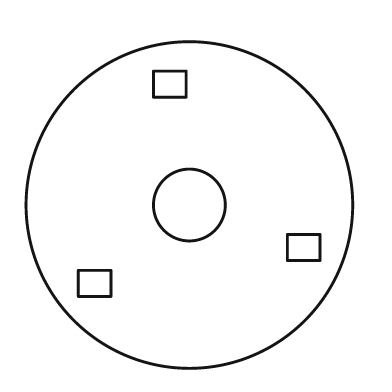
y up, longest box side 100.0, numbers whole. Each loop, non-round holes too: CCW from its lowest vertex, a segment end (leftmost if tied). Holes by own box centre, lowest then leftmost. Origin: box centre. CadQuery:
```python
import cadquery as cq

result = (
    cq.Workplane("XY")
    .moveTo(0.0, 0.0)
    .circle(50.0)
    .moveTo(-34.0, -28.0)
    .lineTo(-24.0, -28.0)
    .lineTo(-24.0, -20.0)
    .lineTo(-34.0, -20.0)
    .close()
    .moveTo(30.0, -17.0)
    .lineTo(40.0, -17.0)
    .lineTo(40.0, -9.0)
    .lineTo(30.0, -9.0)
    .close()
    .moveTo(0.0, 0.0)
    .circle(11.0)
    .moveTo(-11.0, 33.0)
    .lineTo(-1.0, 33.0)
    .lineTo(-1.0, 41.0)
    .lineTo(-11.0, 41.0)
    .close()
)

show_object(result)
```